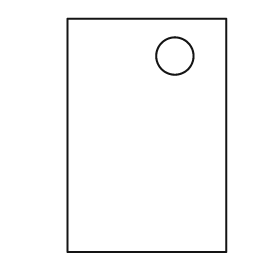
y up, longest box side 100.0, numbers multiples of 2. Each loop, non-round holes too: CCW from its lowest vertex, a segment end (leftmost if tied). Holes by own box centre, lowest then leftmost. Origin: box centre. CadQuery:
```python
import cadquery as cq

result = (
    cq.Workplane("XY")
    .moveTo(-34.0, -50.0)
    .lineTo(34.0, -50.0)
    .lineTo(34.0, 50.0)
    .lineTo(-34.0, 50.0)
    .close()
    .moveTo(12.0, 34.0)
    .circle(8.0)
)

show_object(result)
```